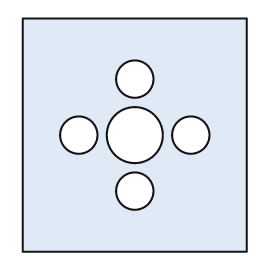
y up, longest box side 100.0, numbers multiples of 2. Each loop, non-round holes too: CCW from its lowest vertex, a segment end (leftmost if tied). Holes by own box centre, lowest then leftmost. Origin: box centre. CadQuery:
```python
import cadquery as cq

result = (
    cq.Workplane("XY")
    .moveTo(-48.0, -50.0)
    .lineTo(48.0, -50.0)
    .lineTo(48.0, 50.0)
    .lineTo(-48.0, 50.0)
    .close()
    .moveTo(0.0, -24.0)
    .circle(8.0)
    .moveTo(-24.0, 0.0)
    .circle(8.0)
    .moveTo(0.0, 0.0)
    .circle(12.0)
    .moveTo(24.0, 0.0)
    .circle(8.0)
    .moveTo(0.0, 24.0)
    .circle(8.0)
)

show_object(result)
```